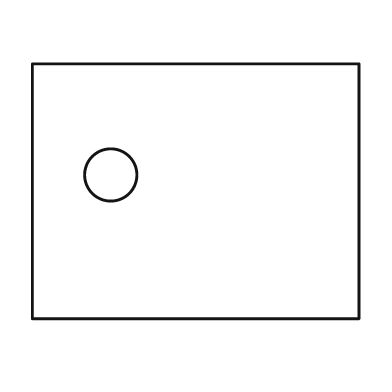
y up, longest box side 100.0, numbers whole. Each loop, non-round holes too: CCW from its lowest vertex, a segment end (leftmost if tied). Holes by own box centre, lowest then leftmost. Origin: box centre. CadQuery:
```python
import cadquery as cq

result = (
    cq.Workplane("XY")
    .moveTo(-50.0, -39.0)
    .lineTo(50.0, -39.0)
    .lineTo(50.0, 39.0)
    .lineTo(-50.0, 39.0)
    .close()
    .moveTo(-26.0, 5.0)
    .circle(8.0)
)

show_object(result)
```